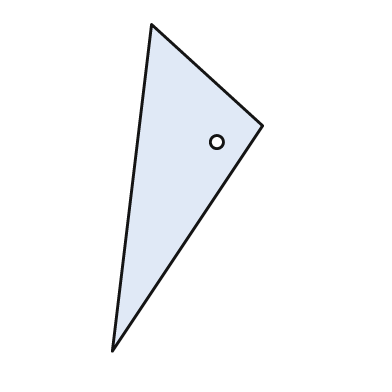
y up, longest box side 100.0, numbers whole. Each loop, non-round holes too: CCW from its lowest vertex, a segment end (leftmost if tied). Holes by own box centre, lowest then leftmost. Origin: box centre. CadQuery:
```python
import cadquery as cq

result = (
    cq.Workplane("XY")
    .moveTo(-23.0, -50.0)
    .lineTo(23.0, 19.0)
    .lineTo(-11.0, 50.0)
    .close()
    .moveTo(9.0, 14.0)
    .circle(2.0)
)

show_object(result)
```